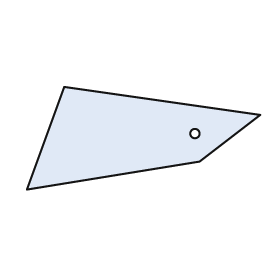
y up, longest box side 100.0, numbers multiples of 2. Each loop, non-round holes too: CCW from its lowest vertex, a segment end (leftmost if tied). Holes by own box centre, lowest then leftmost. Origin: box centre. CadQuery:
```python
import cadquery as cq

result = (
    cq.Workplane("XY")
    .moveTo(-50.0, -22.0)
    .lineTo(24.0, -10.0)
    .lineTo(50.0, 10.0)
    .lineTo(-34.0, 22.0)
    .close()
    .moveTo(22.0, 2.0)
    .circle(2.0)
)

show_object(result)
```